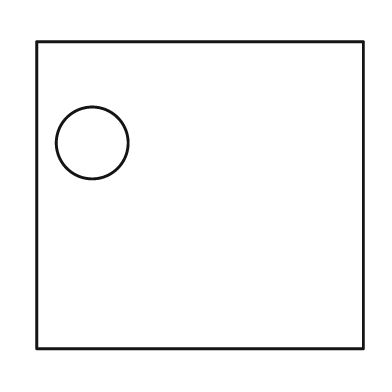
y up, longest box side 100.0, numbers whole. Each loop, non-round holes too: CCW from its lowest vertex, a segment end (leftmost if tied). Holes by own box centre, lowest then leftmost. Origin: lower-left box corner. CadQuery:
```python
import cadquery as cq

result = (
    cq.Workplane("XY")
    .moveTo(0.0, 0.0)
    .lineTo(100.0, 0.0)
    .lineTo(100.0, 94.0)
    .lineTo(0.0, 94.0)
    .close()
    .moveTo(17.0, 63.0)
    .circle(11.0)
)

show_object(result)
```